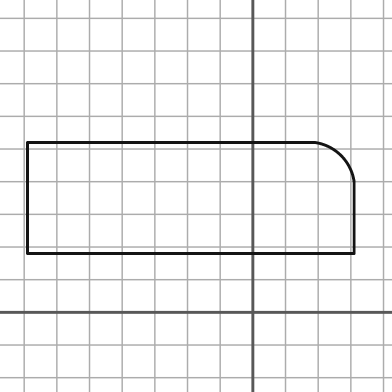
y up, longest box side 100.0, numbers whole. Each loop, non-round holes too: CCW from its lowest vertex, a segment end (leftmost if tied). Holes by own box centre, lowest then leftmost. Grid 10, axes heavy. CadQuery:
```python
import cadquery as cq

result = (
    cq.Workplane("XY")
    .moveTo(-69.0, 18.0)
    .lineTo(31.0, 18.0)
    .lineTo(31.0, 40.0)
    .threePointArc((27.0, 48.0), (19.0, 52.0))
    .lineTo(-69.0, 52.0)
    .close()
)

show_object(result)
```